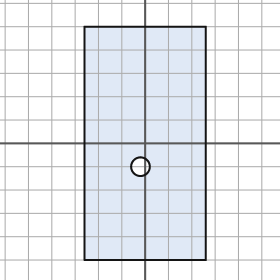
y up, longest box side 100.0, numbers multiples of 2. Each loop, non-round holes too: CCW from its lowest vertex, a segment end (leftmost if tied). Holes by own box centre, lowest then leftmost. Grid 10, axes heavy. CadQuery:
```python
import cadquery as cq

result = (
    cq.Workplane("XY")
    .moveTo(-26.0, -50.0)
    .lineTo(26.0, -50.0)
    .lineTo(26.0, 50.0)
    .lineTo(-26.0, 50.0)
    .close()
    .moveTo(-2.0, -10.0)
    .circle(4.0)
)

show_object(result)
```